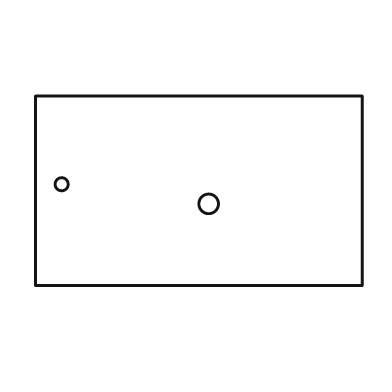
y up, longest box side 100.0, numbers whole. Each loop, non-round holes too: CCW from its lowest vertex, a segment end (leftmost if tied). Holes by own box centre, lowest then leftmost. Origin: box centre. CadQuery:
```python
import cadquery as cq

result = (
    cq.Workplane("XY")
    .moveTo(-50.0, -29.0)
    .lineTo(50.0, -29.0)
    .lineTo(50.0, 29.0)
    .lineTo(-50.0, 29.0)
    .close()
    .moveTo(3.0, -4.0)
    .circle(3.0)
    .moveTo(-42.0, 2.0)
    .circle(2.0)
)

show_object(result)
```